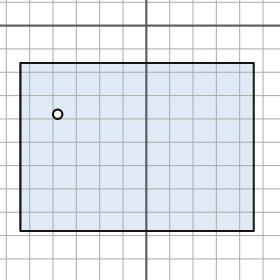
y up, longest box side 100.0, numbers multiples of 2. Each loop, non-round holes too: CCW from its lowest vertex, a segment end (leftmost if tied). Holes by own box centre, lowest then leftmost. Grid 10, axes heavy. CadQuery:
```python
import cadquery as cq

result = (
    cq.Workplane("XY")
    .moveTo(-54.0, -88.0)
    .lineTo(46.0, -88.0)
    .lineTo(46.0, -16.0)
    .lineTo(-54.0, -16.0)
    .close()
    .moveTo(-38.0, -38.0)
    .circle(2.0)
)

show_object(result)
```